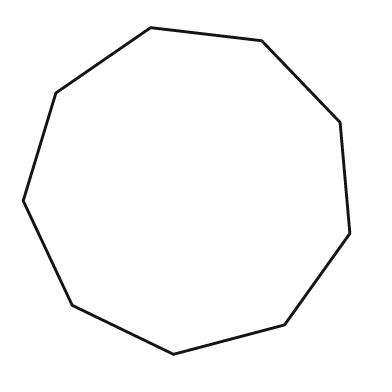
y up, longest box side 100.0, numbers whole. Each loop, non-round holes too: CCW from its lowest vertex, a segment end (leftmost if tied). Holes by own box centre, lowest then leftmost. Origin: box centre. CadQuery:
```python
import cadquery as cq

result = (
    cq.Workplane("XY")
    .moveTo(-4.0, -50.0)
    .lineTo(30.0, -41.0)
    .lineTo(50.0, -13.0)
    .lineTo(47.0, 21.0)
    .lineTo(23.0, 46.0)
    .lineTo(-11.0, 50.0)
    .lineTo(-40.0, 30.0)
    .lineTo(-50.0, -3.0)
    .lineTo(-35.0, -35.0)
    .close()
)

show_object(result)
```